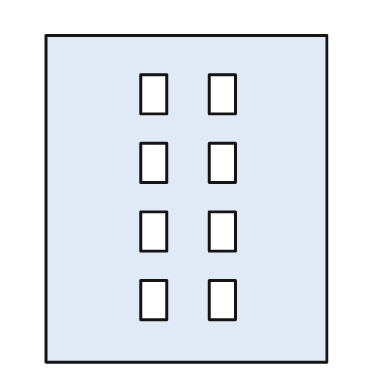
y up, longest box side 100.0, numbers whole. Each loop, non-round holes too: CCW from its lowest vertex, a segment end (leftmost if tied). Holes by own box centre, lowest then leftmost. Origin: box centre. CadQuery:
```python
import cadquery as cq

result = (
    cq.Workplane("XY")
    .moveTo(-43.0, -50.0)
    .lineTo(43.0, -50.0)
    .lineTo(43.0, 50.0)
    .lineTo(-43.0, 50.0)
    .close()
    .moveTo(-14.0, -37.0)
    .lineTo(-6.0, -37.0)
    .lineTo(-6.0, -25.0)
    .lineTo(-14.0, -25.0)
    .close()
    .moveTo(7.0, -37.0)
    .lineTo(15.0, -37.0)
    .lineTo(15.0, -25.0)
    .lineTo(7.0, -25.0)
    .close()
    .moveTo(-14.0, -16.0)
    .lineTo(-6.0, -16.0)
    .lineTo(-6.0, -4.0)
    .lineTo(-14.0, -4.0)
    .close()
    .moveTo(7.0, -16.0)
    .lineTo(15.0, -16.0)
    .lineTo(15.0, -4.0)
    .lineTo(7.0, -4.0)
    .close()
    .moveTo(-14.0, 5.0)
    .lineTo(-6.0, 5.0)
    .lineTo(-6.0, 17.0)
    .lineTo(-14.0, 17.0)
    .close()
    .moveTo(7.0, 5.0)
    .lineTo(15.0, 5.0)
    .lineTo(15.0, 17.0)
    .lineTo(7.0, 17.0)
    .close()
    .moveTo(-14.0, 26.0)
    .lineTo(-6.0, 26.0)
    .lineTo(-6.0, 38.0)
    .lineTo(-14.0, 38.0)
    .close()
    .moveTo(7.0, 26.0)
    .lineTo(15.0, 26.0)
    .lineTo(15.0, 38.0)
    .lineTo(7.0, 38.0)
    .close()
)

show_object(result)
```